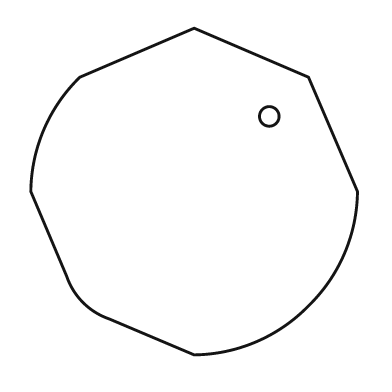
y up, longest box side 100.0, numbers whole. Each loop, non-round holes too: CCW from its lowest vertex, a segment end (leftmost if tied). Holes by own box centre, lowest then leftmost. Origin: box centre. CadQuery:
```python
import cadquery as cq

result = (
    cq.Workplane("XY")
    .moveTo(0.0, -50.0)
    .threePointArc((19.0, -46.0), (35.0, -35.0))
    .threePointArc((46.0, -19.0), (50.0, 0.0))
    .lineTo(35.0, 35.0)
    .lineTo(0.0, 50.0)
    .lineTo(-35.0, 35.0)
    .threePointArc((-46.0, 19.0), (-50.0, 0.0))
    .lineTo(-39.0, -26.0)
    .threePointArc((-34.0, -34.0), (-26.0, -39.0))
    .close()
    .moveTo(23.0, 23.0)
    .circle(3.0)
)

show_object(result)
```